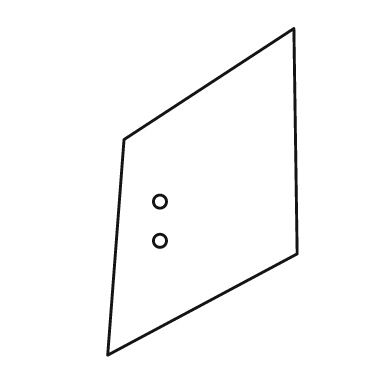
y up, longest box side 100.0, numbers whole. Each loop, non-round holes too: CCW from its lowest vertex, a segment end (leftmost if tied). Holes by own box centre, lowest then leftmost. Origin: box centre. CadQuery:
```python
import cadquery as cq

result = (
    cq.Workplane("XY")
    .moveTo(-29.0, -50.0)
    .lineTo(29.0, -19.0)
    .lineTo(28.0, 50.0)
    .lineTo(-24.0, 16.0)
    .close()
    .moveTo(-13.0, -15.0)
    .circle(2.0)
    .moveTo(-13.0, -3.0)
    .circle(2.0)
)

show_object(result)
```